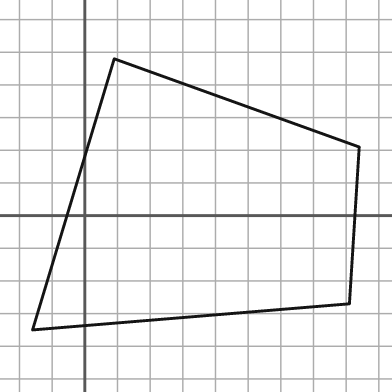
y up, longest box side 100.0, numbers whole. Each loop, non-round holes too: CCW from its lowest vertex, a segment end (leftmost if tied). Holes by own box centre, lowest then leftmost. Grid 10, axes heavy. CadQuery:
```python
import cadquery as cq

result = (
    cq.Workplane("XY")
    .moveTo(-16.0, -35.0)
    .lineTo(81.0, -27.0)
    .lineTo(84.0, 21.0)
    .lineTo(9.0, 48.0)
    .close()
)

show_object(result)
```